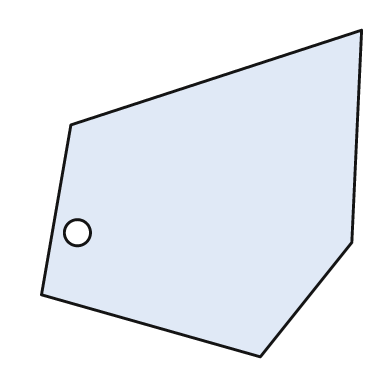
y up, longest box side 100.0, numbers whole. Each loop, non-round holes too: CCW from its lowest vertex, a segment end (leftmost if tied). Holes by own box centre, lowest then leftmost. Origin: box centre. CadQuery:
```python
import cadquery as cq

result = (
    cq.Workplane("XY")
    .moveTo(18.0, -50.0)
    .lineTo(46.0, -15.0)
    .lineTo(49.0, 50.0)
    .lineTo(-40.0, 21.0)
    .lineTo(-49.0, -31.0)
    .close()
    .moveTo(-38.0, -12.0)
    .circle(4.0)
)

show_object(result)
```